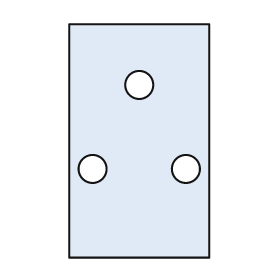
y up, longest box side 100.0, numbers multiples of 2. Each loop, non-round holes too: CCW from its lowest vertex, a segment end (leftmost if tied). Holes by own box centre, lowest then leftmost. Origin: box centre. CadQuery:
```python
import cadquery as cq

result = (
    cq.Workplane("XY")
    .moveTo(-30.0, -50.0)
    .lineTo(30.0, -50.0)
    .lineTo(30.0, 50.0)
    .lineTo(-30.0, 50.0)
    .close()
    .moveTo(-20.0, -12.0)
    .circle(6.0)
    .moveTo(20.0, -12.0)
    .circle(6.0)
    .moveTo(0.0, 24.0)
    .circle(6.0)
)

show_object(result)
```